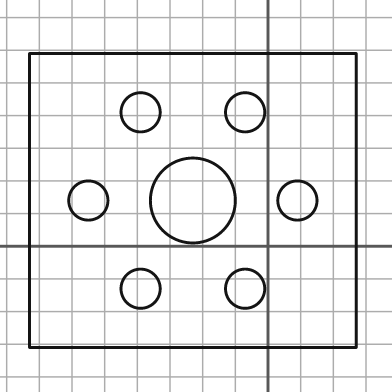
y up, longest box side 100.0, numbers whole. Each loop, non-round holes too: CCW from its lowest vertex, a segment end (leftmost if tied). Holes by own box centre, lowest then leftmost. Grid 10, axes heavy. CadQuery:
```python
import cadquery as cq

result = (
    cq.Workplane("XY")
    .moveTo(-73.0, -31.0)
    .lineTo(27.0, -31.0)
    .lineTo(27.0, 59.0)
    .lineTo(-73.0, 59.0)
    .close()
    .moveTo(-39.0, -13.0)
    .circle(6.0)
    .moveTo(-7.0, -13.0)
    .circle(6.0)
    .moveTo(-55.0, 14.0)
    .circle(6.0)
    .moveTo(-23.0, 14.0)
    .circle(13.0)
    .moveTo(9.0, 14.0)
    .circle(6.0)
    .moveTo(-39.0, 41.0)
    .circle(6.0)
    .moveTo(-7.0, 41.0)
    .circle(6.0)
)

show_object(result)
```